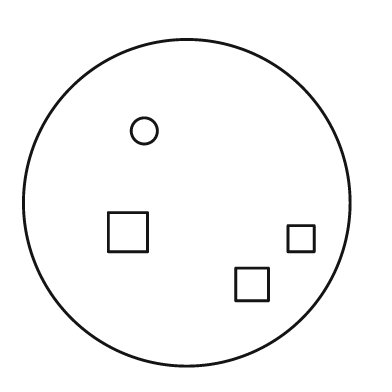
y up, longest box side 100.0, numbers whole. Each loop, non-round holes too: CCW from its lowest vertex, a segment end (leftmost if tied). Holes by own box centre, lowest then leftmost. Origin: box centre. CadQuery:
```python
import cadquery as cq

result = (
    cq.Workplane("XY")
    .moveTo(0.0, 0.0)
    .circle(50.0)
    .moveTo(15.0, -30.0)
    .lineTo(25.0, -30.0)
    .lineTo(25.0, -20.0)
    .lineTo(15.0, -20.0)
    .close()
    .moveTo(31.0, -15.0)
    .lineTo(39.0, -15.0)
    .lineTo(39.0, -7.0)
    .lineTo(31.0, -7.0)
    .close()
    .moveTo(-24.0, -15.0)
    .lineTo(-12.0, -15.0)
    .lineTo(-12.0, -3.0)
    .lineTo(-24.0, -3.0)
    .close()
    .moveTo(-13.0, 22.0)
    .circle(4.0)
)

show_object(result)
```